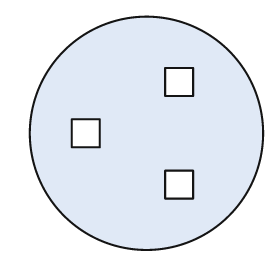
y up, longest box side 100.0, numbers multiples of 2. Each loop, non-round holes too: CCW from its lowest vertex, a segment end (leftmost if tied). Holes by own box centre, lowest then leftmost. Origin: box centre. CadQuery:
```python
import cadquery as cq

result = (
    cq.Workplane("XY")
    .moveTo(0.0, 0.0)
    .circle(50.0)
    .moveTo(8.0, -28.0)
    .lineTo(20.0, -28.0)
    .lineTo(20.0, -16.0)
    .lineTo(8.0, -16.0)
    .close()
    .moveTo(-32.0, -6.0)
    .lineTo(-20.0, -6.0)
    .lineTo(-20.0, 6.0)
    .lineTo(-32.0, 6.0)
    .close()
    .moveTo(8.0, 16.0)
    .lineTo(20.0, 16.0)
    .lineTo(20.0, 28.0)
    .lineTo(8.0, 28.0)
    .close()
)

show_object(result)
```